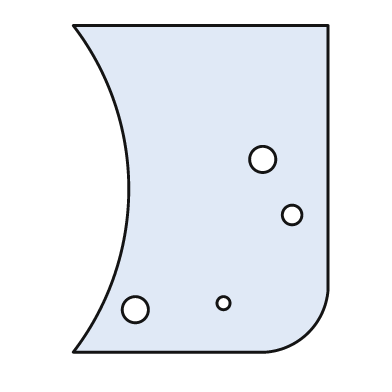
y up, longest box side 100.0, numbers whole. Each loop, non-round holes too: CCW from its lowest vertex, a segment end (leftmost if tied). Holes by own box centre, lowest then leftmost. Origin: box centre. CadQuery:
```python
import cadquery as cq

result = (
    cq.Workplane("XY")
    .moveTo(-39.0, -50.0)
    .lineTo(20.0, -50.0)
    .threePointArc((33.0, -44.0), (39.0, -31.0))
    .lineTo(39.0, 50.0)
    .lineTo(-39.0, 50.0)
    .threePointArc((-22.0, 0.0), (-39.0, -50.0))
    .close()
    .moveTo(-20.0, -37.0)
    .circle(4.0)
    .moveTo(7.0, -35.0)
    .circle(2.0)
    .moveTo(28.0, -8.0)
    .circle(3.0)
    .moveTo(19.0, 9.0)
    .circle(4.0)
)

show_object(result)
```